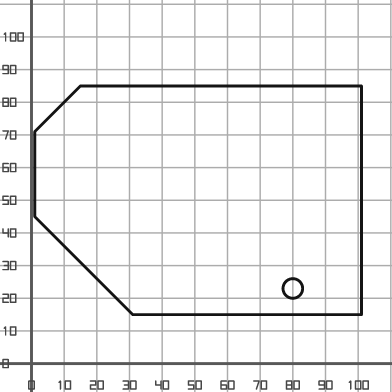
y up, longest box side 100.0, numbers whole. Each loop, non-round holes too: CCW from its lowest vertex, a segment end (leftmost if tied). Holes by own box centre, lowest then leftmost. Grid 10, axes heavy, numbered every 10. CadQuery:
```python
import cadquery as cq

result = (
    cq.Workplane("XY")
    .moveTo(31.0, 15.0)
    .lineTo(101.0, 15.0)
    .lineTo(101.0, 85.0)
    .lineTo(15.0, 85.0)
    .lineTo(1.0, 71.0)
    .lineTo(1.0, 45.0)
    .close()
    .moveTo(80.0, 23.0)
    .circle(3.0)
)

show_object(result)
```